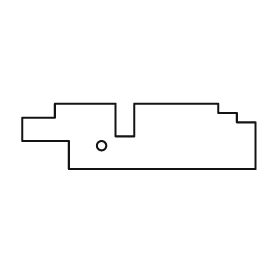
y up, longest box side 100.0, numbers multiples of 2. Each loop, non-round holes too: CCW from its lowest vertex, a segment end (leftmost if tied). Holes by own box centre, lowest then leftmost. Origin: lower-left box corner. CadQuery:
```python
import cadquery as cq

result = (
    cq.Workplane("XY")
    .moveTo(20.0, 0.0)
    .lineTo(100.0, 0.0)
    .lineTo(100.0, 20.0)
    .lineTo(92.0, 20.0)
    .lineTo(92.0, 24.0)
    .lineTo(84.0, 24.0)
    .lineTo(84.0, 28.0)
    .lineTo(48.0, 28.0)
    .lineTo(48.0, 14.0)
    .lineTo(40.0, 14.0)
    .lineTo(40.0, 28.0)
    .lineTo(14.0, 28.0)
    .lineTo(14.0, 22.0)
    .lineTo(0.0, 22.0)
    .lineTo(0.0, 12.0)
    .lineTo(20.0, 12.0)
    .close()
    .moveTo(34.0, 10.0)
    .circle(2.0)
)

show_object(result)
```